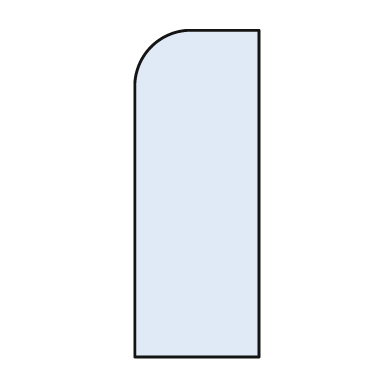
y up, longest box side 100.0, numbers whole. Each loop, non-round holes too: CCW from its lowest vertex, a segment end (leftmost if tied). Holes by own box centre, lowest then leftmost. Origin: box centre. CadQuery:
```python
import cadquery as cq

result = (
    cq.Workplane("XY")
    .moveTo(-19.0, -50.0)
    .lineTo(19.0, -50.0)
    .lineTo(19.0, 50.0)
    .lineTo(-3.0, 50.0)
    .threePointArc((-14.0, 45.0), (-19.0, 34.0))
    .close()
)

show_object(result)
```